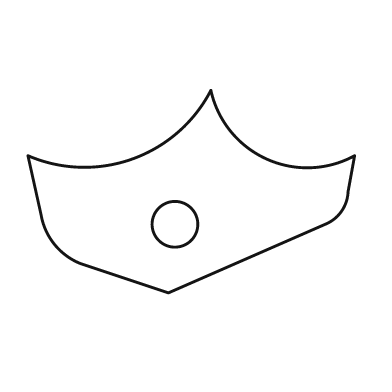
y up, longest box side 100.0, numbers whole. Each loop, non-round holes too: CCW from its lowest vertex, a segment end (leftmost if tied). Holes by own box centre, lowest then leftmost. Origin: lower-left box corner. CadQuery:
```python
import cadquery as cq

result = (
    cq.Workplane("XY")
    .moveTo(43.0, 0.0)
    .lineTo(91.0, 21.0)
    .threePointArc((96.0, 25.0), (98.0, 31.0))
    .lineTo(100.0, 42.0)
    .threePointArc((73.0, 41.0), (56.0, 62.0))
    .threePointArc((32.0, 41.0), (0.0, 42.0))
    .lineTo(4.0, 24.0)
    .threePointArc((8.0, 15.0), (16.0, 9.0))
    .close()
    .moveTo(45.0, 21.0)
    .circle(7.0)
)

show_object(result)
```